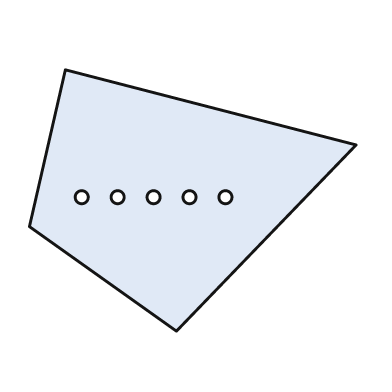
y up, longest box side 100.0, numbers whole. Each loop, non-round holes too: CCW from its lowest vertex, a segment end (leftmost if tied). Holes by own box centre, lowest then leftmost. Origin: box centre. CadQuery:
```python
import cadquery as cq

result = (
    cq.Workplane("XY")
    .moveTo(-5.0, -40.0)
    .lineTo(50.0, 17.0)
    .lineTo(-39.0, 40.0)
    .lineTo(-50.0, -8.0)
    .close()
    .moveTo(-34.0, 1.0)
    .circle(2.0)
    .moveTo(-23.0, 1.0)
    .circle(2.0)
    .moveTo(-12.0, 1.0)
    .circle(2.0)
    .moveTo(-1.0, 1.0)
    .circle(2.0)
    .moveTo(10.0, 1.0)
    .circle(2.0)
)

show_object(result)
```